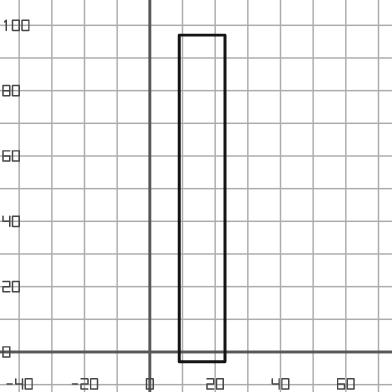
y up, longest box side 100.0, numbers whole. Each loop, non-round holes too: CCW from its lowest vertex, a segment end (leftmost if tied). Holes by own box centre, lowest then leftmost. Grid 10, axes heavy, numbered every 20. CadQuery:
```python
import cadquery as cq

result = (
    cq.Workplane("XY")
    .moveTo(9.0, -3.0)
    .lineTo(23.0, -3.0)
    .lineTo(23.0, 97.0)
    .lineTo(9.0, 97.0)
    .close()
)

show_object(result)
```